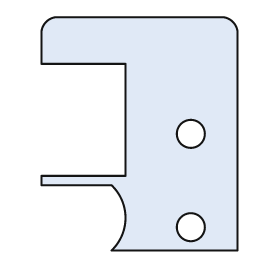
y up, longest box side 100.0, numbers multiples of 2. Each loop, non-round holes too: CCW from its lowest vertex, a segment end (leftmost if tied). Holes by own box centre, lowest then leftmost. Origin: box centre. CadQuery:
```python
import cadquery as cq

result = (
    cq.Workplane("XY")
    .moveTo(-12.0, -50.0)
    .lineTo(42.0, -50.0)
    .lineTo(42.0, 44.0)
    .threePointArc((40.0, 48.0), (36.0, 50.0))
    .lineTo(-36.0, 50.0)
    .threePointArc((-40.0, 48.0), (-42.0, 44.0))
    .lineTo(-42.0, 30.0)
    .lineTo(-6.0, 30.0)
    .lineTo(-6.0, -18.0)
    .lineTo(-42.0, -18.0)
    .lineTo(-42.0, -22.0)
    .lineTo(-12.0, -22.0)
    .threePointArc((-6.0, -36.0), (-12.0, -50.0))
    .close()
    .moveTo(22.0, -40.0)
    .circle(6.0)
    .moveTo(22.0, 0.0)
    .circle(6.0)
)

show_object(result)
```